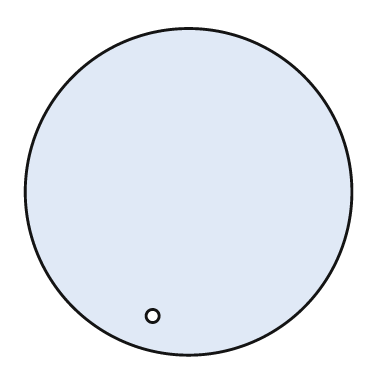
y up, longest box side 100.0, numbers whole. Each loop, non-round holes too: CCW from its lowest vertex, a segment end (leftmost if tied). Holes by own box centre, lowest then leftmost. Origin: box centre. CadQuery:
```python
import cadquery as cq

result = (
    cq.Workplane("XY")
    .moveTo(0.0, 0.0)
    .circle(50.0)
    .moveTo(-11.0, -38.0)
    .circle(2.0)
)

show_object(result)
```